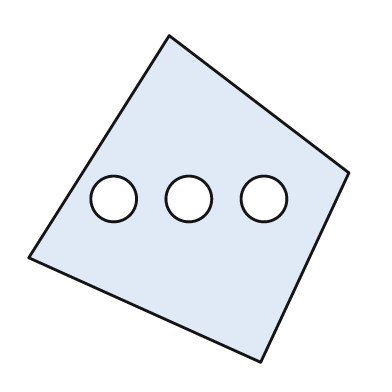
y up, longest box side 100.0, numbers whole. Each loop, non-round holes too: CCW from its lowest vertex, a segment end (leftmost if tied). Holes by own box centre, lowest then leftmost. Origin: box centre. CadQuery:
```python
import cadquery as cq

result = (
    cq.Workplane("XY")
    .moveTo(22.0, -50.0)
    .lineTo(49.0, 8.0)
    .lineTo(-6.0, 50.0)
    .lineTo(-49.0, -18.0)
    .close()
    .moveTo(-23.0, 0.0)
    .circle(7.0)
    .moveTo(0.0, 0.0)
    .circle(7.0)
    .moveTo(23.0, 0.0)
    .circle(7.0)
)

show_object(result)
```